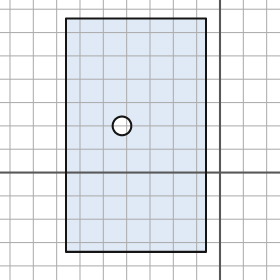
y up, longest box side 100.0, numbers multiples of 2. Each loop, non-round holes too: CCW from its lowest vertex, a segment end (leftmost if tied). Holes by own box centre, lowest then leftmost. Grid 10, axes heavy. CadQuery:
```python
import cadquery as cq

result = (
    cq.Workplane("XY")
    .moveTo(-66.0, -34.0)
    .lineTo(-6.0, -34.0)
    .lineTo(-6.0, 66.0)
    .lineTo(-66.0, 66.0)
    .close()
    .moveTo(-42.0, 20.0)
    .circle(4.0)
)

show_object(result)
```